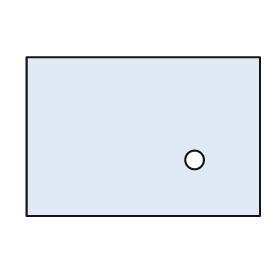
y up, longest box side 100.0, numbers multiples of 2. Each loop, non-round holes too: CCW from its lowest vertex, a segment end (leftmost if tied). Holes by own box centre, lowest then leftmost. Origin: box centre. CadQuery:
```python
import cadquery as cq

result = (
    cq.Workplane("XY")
    .moveTo(-50.0, -34.0)
    .lineTo(50.0, -34.0)
    .lineTo(50.0, 34.0)
    .lineTo(-50.0, 34.0)
    .close()
    .moveTo(22.0, -10.0)
    .circle(4.0)
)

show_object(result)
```